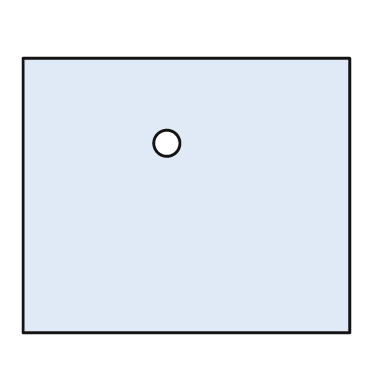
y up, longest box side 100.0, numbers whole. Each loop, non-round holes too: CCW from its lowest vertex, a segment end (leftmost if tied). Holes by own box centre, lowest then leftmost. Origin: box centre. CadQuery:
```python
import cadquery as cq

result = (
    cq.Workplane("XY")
    .moveTo(-50.0, -42.0)
    .lineTo(50.0, -42.0)
    .lineTo(50.0, 42.0)
    .lineTo(-50.0, 42.0)
    .close()
    .moveTo(-6.0, 16.0)
    .circle(4.0)
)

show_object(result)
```